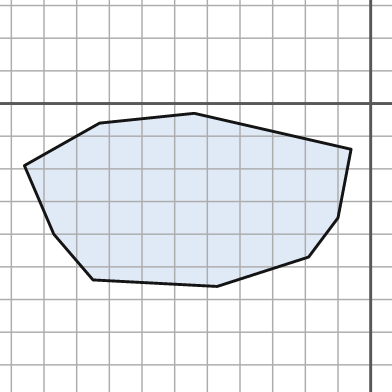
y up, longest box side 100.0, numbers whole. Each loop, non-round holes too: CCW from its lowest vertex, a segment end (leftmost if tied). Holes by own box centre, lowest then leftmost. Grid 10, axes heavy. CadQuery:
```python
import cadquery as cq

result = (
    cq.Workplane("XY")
    .moveTo(-47.0, -56.0)
    .lineTo(-19.0, -47.0)
    .lineTo(-10.0, -35.0)
    .lineTo(-6.0, -14.0)
    .lineTo(-54.0, -3.0)
    .lineTo(-83.0, -6.0)
    .lineTo(-106.0, -19.0)
    .lineTo(-97.0, -40.0)
    .lineTo(-85.0, -54.0)
    .close()
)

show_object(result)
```